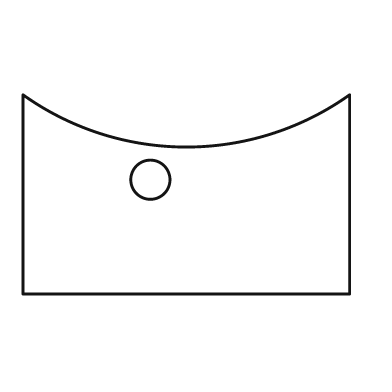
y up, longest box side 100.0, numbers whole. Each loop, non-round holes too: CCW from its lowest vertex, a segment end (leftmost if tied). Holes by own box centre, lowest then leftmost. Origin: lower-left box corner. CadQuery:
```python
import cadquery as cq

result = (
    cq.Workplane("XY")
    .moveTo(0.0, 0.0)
    .lineTo(100.0, 0.0)
    .lineTo(100.0, 61.0)
    .threePointArc((50.0, 45.0), (0.0, 61.0))
    .close()
    .moveTo(39.0, 35.0)
    .circle(6.0)
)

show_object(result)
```